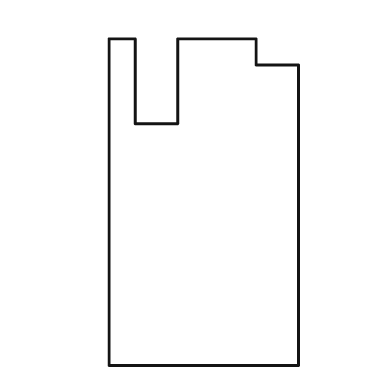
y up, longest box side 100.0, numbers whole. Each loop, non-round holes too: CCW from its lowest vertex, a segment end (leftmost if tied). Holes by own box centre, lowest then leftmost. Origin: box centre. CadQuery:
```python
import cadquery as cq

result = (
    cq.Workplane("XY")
    .moveTo(-29.0, -50.0)
    .lineTo(29.0, -50.0)
    .lineTo(29.0, 42.0)
    .lineTo(16.0, 42.0)
    .lineTo(16.0, 50.0)
    .lineTo(-8.0, 50.0)
    .lineTo(-8.0, 24.0)
    .lineTo(-21.0, 24.0)
    .lineTo(-21.0, 50.0)
    .lineTo(-29.0, 50.0)
    .close()
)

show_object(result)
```